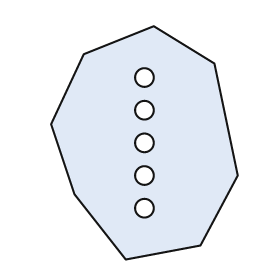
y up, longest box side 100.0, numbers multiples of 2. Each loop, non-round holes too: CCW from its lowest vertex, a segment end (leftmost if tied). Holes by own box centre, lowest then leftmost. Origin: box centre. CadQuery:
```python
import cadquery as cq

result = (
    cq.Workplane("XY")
    .moveTo(-8.0, -50.0)
    .lineTo(24.0, -44.0)
    .lineTo(40.0, -14.0)
    .lineTo(30.0, 34.0)
    .lineTo(4.0, 50.0)
    .lineTo(-26.0, 38.0)
    .lineTo(-40.0, 8.0)
    .lineTo(-30.0, -22.0)
    .close()
    .moveTo(0.0, -28.0)
    .circle(4.0)
    .moveTo(0.0, -14.0)
    .circle(4.0)
    .moveTo(0.0, 0.0)
    .circle(4.0)
    .moveTo(0.0, 14.0)
    .circle(4.0)
    .moveTo(0.0, 28.0)
    .circle(4.0)
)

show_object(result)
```